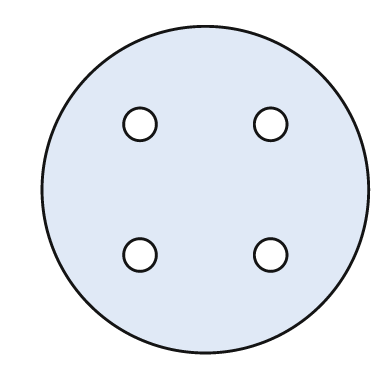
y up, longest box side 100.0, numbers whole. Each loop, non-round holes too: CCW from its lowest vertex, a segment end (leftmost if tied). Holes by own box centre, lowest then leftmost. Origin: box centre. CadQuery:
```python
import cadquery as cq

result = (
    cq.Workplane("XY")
    .moveTo(0.0, 0.0)
    .circle(50.0)
    .moveTo(-20.0, -20.0)
    .circle(5.0)
    .moveTo(20.0, -20.0)
    .circle(5.0)
    .moveTo(-20.0, 20.0)
    .circle(5.0)
    .moveTo(20.0, 20.0)
    .circle(5.0)
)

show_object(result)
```